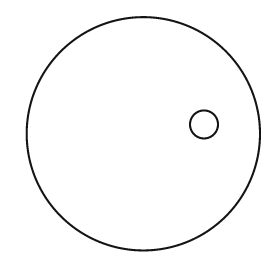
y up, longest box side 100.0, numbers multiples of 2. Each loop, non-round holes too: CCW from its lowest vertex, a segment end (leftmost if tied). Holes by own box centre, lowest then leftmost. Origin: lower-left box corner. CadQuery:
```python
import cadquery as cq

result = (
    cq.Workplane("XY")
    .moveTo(50.0, 50.0)
    .circle(50.0)
    .moveTo(76.0, 54.0)
    .circle(6.0)
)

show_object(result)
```